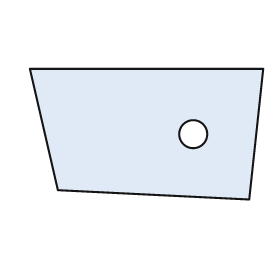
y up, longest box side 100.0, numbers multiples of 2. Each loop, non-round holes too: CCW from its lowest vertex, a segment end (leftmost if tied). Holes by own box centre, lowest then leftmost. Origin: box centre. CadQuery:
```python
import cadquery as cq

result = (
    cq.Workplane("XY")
    .moveTo(44.0, -28.0)
    .lineTo(50.0, 28.0)
    .lineTo(-50.0, 28.0)
    .lineTo(-38.0, -24.0)
    .close()
    .moveTo(20.0, 0.0)
    .circle(6.0)
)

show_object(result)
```